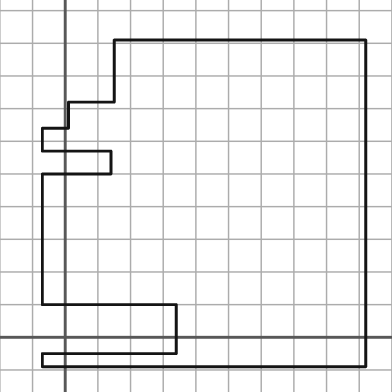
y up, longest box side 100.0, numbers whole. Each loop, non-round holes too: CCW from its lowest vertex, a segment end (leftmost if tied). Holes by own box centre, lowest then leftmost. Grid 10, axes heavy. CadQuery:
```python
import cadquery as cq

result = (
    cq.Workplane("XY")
    .moveTo(-7.0, -9.0)
    .lineTo(92.0, -9.0)
    .lineTo(92.0, 91.0)
    .lineTo(15.0, 91.0)
    .lineTo(15.0, 72.0)
    .lineTo(1.0, 72.0)
    .lineTo(1.0, 64.0)
    .lineTo(-7.0, 64.0)
    .lineTo(-7.0, 57.0)
    .lineTo(14.0, 57.0)
    .lineTo(14.0, 50.0)
    .lineTo(-7.0, 50.0)
    .lineTo(-7.0, 10.0)
    .lineTo(34.0, 10.0)
    .lineTo(34.0, -5.0)
    .lineTo(-7.0, -5.0)
    .close()
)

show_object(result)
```